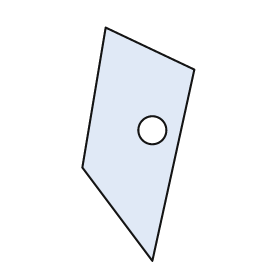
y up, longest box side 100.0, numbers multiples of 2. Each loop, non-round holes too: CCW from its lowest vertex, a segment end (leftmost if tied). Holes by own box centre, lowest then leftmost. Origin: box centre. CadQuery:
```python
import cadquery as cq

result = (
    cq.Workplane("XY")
    .moveTo(6.0, -50.0)
    .lineTo(24.0, 32.0)
    .lineTo(-14.0, 50.0)
    .lineTo(-24.0, -10.0)
    .close()
    .moveTo(6.0, 6.0)
    .circle(6.0)
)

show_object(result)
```